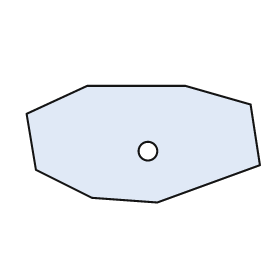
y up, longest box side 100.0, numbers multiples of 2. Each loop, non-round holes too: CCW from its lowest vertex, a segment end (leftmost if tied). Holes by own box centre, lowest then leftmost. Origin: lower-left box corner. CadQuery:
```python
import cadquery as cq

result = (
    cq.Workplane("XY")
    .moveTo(56.0, 0.0)
    .lineTo(100.0, 16.0)
    .lineTo(96.0, 42.0)
    .lineTo(68.0, 50.0)
    .lineTo(26.0, 50.0)
    .lineTo(0.0, 38.0)
    .lineTo(4.0, 14.0)
    .lineTo(28.0, 2.0)
    .close()
    .moveTo(52.0, 22.0)
    .circle(4.0)
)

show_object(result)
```